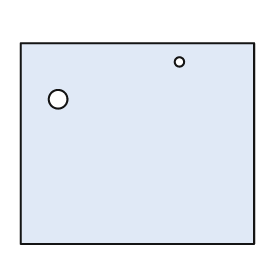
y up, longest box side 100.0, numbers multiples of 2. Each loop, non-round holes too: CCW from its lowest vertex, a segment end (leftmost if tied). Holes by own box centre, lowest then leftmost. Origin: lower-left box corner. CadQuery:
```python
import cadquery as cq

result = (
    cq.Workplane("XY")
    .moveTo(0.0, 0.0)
    .lineTo(100.0, 0.0)
    .lineTo(100.0, 86.0)
    .lineTo(0.0, 86.0)
    .close()
    .moveTo(16.0, 62.0)
    .circle(4.0)
    .moveTo(68.0, 78.0)
    .circle(2.0)
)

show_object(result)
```